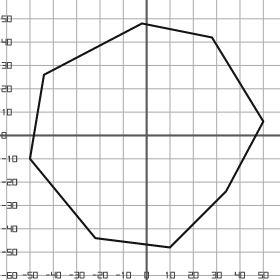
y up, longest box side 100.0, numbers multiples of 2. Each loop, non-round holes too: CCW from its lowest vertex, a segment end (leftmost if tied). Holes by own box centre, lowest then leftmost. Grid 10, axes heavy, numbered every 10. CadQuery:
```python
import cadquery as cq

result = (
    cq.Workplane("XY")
    .moveTo(10.0, -48.0)
    .lineTo(34.0, -24.0)
    .lineTo(50.0, 6.0)
    .lineTo(28.0, 42.0)
    .lineTo(-2.0, 48.0)
    .lineTo(-44.0, 26.0)
    .lineTo(-50.0, -10.0)
    .lineTo(-22.0, -44.0)
    .close()
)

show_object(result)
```